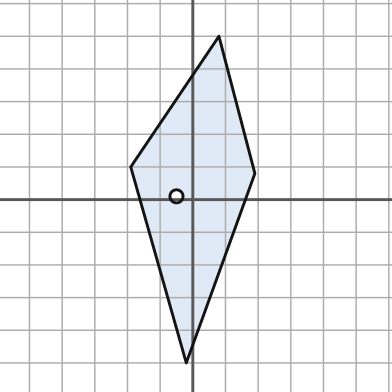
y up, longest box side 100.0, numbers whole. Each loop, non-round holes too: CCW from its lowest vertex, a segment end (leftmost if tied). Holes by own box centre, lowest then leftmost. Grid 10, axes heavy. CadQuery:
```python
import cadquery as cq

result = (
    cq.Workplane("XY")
    .moveTo(-2.0, -50.0)
    .lineTo(19.0, 8.0)
    .lineTo(8.0, 50.0)
    .lineTo(-19.0, 10.0)
    .close()
    .moveTo(-5.0, 1.0)
    .circle(2.0)
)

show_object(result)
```